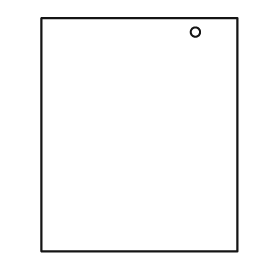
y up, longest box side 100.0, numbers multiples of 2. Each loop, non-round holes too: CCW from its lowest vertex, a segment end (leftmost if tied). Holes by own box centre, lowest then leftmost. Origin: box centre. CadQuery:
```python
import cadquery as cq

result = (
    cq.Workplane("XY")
    .moveTo(-42.0, -50.0)
    .lineTo(42.0, -50.0)
    .lineTo(42.0, 50.0)
    .lineTo(-42.0, 50.0)
    .close()
    .moveTo(24.0, 44.0)
    .circle(2.0)
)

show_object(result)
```